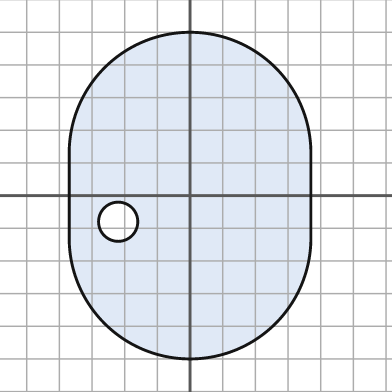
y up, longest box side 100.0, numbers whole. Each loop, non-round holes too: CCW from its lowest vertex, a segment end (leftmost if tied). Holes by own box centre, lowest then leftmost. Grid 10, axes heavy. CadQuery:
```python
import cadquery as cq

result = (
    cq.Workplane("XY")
    .moveTo(-37.0, -13.0)
    .threePointArc((0.0, -50.0), (37.0, -13.0))
    .lineTo(37.0, 13.0)
    .threePointArc((0.0, 50.0), (-37.0, 13.0))
    .close()
    .moveTo(-22.0, -8.0)
    .circle(6.0)
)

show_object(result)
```